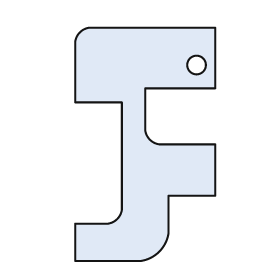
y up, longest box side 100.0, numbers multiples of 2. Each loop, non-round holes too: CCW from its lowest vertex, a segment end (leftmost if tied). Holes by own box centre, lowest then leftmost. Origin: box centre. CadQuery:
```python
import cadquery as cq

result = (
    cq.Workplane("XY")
    .moveTo(-30.0, -50.0)
    .lineTo(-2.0, -50.0)
    .threePointArc((6.0, -46.0), (10.0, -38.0))
    .lineTo(10.0, -22.0)
    .lineTo(30.0, -22.0)
    .lineTo(30.0, 0.0)
    .lineTo(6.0, 0.0)
    .threePointArc((2.0, 2.0), (0.0, 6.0))
    .lineTo(0.0, 24.0)
    .lineTo(30.0, 24.0)
    .lineTo(30.0, 50.0)
    .lineTo(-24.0, 50.0)
    .threePointArc((-28.0, 48.0), (-30.0, 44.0))
    .lineTo(-30.0, 18.0)
    .lineTo(-10.0, 18.0)
    .lineTo(-10.0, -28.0)
    .threePointArc((-12.0, -32.0), (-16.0, -34.0))
    .lineTo(-30.0, -34.0)
    .close()
    .moveTo(22.0, 34.0)
    .circle(4.0)
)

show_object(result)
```